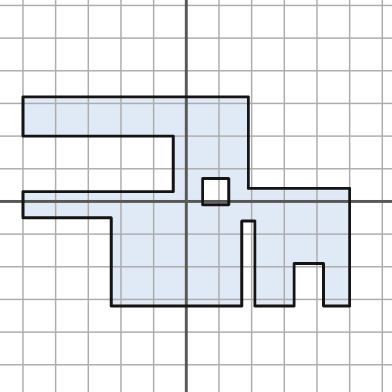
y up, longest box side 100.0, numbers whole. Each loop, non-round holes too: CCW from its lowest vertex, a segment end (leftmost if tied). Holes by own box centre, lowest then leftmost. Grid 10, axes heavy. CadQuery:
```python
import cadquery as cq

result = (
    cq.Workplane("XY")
    .moveTo(-23.0, -32.0)
    .lineTo(17.0, -32.0)
    .lineTo(17.0, -6.0)
    .lineTo(21.0, -6.0)
    .lineTo(21.0, -32.0)
    .lineTo(33.0, -32.0)
    .lineTo(33.0, -19.0)
    .lineTo(42.0, -19.0)
    .lineTo(42.0, -32.0)
    .lineTo(50.0, -32.0)
    .lineTo(50.0, 4.0)
    .lineTo(19.0, 4.0)
    .lineTo(19.0, 32.0)
    .lineTo(-50.0, 32.0)
    .lineTo(-50.0, 20.0)
    .lineTo(-4.0, 20.0)
    .lineTo(-4.0, 3.0)
    .lineTo(-50.0, 3.0)
    .lineTo(-50.0, -5.0)
    .lineTo(-23.0, -5.0)
    .close()
    .moveTo(5.0, -1.0)
    .lineTo(13.0, -1.0)
    .lineTo(13.0, 7.0)
    .lineTo(5.0, 7.0)
    .close()
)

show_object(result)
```